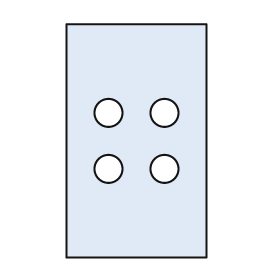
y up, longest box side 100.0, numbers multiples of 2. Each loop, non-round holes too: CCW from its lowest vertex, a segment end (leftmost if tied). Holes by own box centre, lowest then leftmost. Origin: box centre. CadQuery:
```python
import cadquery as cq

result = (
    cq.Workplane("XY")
    .moveTo(-30.0, -50.0)
    .lineTo(30.0, -50.0)
    .lineTo(30.0, 50.0)
    .lineTo(-30.0, 50.0)
    .close()
    .moveTo(-12.0, -12.0)
    .circle(6.0)
    .moveTo(12.0, -12.0)
    .circle(6.0)
    .moveTo(-12.0, 12.0)
    .circle(6.0)
    .moveTo(12.0, 12.0)
    .circle(6.0)
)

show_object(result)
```